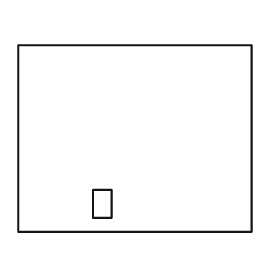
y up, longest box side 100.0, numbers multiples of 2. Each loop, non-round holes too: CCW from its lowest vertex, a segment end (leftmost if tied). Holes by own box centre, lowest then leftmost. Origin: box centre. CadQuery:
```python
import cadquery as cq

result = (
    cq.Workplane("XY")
    .moveTo(-50.0, -40.0)
    .lineTo(50.0, -40.0)
    .lineTo(50.0, 40.0)
    .lineTo(-50.0, 40.0)
    .close()
    .moveTo(-18.0, -34.0)
    .lineTo(-10.0, -34.0)
    .lineTo(-10.0, -22.0)
    .lineTo(-18.0, -22.0)
    .close()
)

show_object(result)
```